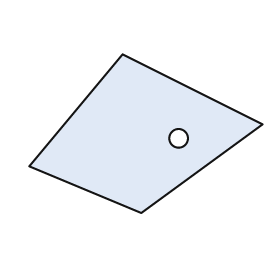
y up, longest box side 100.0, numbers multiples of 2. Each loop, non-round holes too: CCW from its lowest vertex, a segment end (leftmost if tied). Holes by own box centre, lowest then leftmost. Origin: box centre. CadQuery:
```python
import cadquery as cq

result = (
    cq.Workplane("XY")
    .moveTo(-2.0, -34.0)
    .lineTo(50.0, 4.0)
    .lineTo(-10.0, 34.0)
    .lineTo(-50.0, -14.0)
    .close()
    .moveTo(14.0, -2.0)
    .circle(4.0)
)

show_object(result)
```